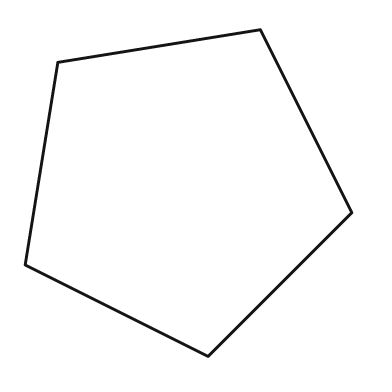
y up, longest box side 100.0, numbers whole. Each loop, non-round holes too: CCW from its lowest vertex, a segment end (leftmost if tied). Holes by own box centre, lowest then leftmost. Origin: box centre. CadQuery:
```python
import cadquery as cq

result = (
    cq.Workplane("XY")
    .moveTo(6.0, -50.0)
    .lineTo(50.0, -6.0)
    .lineTo(22.0, 50.0)
    .lineTo(-40.0, 40.0)
    .lineTo(-50.0, -22.0)
    .close()
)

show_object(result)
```